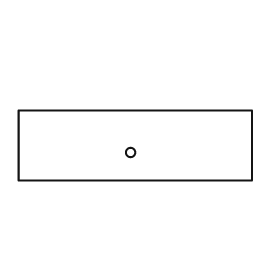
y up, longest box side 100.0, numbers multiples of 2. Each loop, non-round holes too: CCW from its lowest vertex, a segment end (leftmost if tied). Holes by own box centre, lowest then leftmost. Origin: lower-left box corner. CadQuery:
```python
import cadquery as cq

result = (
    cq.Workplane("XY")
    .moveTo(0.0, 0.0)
    .lineTo(100.0, 0.0)
    .lineTo(100.0, 30.0)
    .lineTo(0.0, 30.0)
    .close()
    .moveTo(48.0, 12.0)
    .circle(2.0)
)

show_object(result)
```